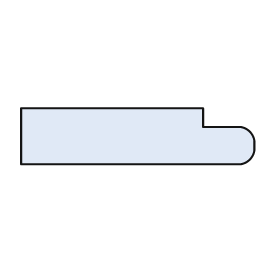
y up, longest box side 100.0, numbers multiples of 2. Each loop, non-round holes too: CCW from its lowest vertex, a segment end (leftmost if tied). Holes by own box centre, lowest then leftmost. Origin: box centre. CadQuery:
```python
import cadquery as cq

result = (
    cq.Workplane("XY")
    .moveTo(-50.0, -12.0)
    .lineTo(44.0, -12.0)
    .threePointArc((48.0, -10.0), (50.0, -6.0))
    .lineTo(50.0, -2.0)
    .threePointArc((48.0, 2.0), (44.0, 4.0))
    .lineTo(28.0, 4.0)
    .lineTo(28.0, 12.0)
    .lineTo(-50.0, 12.0)
    .close()
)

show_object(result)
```